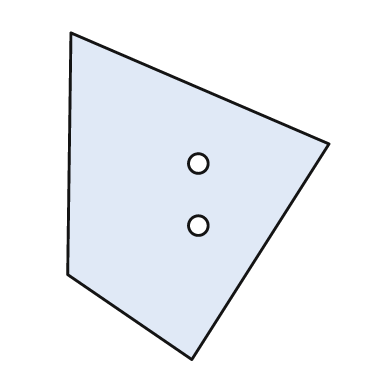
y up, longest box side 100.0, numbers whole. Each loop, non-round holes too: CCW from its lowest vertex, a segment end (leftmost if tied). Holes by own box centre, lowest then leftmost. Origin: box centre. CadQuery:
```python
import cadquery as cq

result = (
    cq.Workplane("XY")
    .moveTo(-2.0, -50.0)
    .lineTo(40.0, 16.0)
    .lineTo(-39.0, 50.0)
    .lineTo(-40.0, -24.0)
    .close()
    .moveTo(0.0, -9.0)
    .circle(3.0)
    .moveTo(0.0, 10.0)
    .circle(3.0)
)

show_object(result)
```